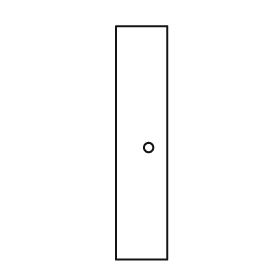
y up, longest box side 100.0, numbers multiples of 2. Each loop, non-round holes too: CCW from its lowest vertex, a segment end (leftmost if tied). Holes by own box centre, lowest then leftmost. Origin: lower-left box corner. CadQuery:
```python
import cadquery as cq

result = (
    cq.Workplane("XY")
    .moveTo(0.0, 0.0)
    .lineTo(22.0, 0.0)
    .lineTo(22.0, 100.0)
    .lineTo(0.0, 100.0)
    .close()
    .moveTo(14.0, 48.0)
    .circle(2.0)
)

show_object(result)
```